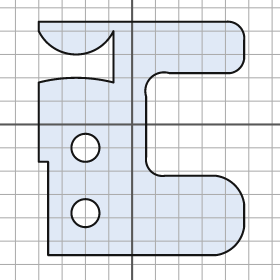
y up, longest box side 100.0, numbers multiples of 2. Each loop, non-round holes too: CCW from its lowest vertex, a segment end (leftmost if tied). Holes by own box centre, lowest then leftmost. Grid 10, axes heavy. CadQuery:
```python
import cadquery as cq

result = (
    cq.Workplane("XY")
    .moveTo(-36.0, -56.0)
    .lineTo(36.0, -56.0)
    .threePointArc((44.0, -52.0), (48.0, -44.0))
    .lineTo(48.0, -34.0)
    .threePointArc((44.0, -26.0), (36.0, -22.0))
    .lineTo(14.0, -22.0)
    .threePointArc((8.0, -20.0), (6.0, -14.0))
    .lineTo(6.0, 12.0)
    .threePointArc((8.0, 20.0), (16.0, 22.0))
    .lineTo(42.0, 22.0)
    .threePointArc((46.0, 24.0), (48.0, 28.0))
    .lineTo(48.0, 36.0)
    .threePointArc((46.0, 42.0), (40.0, 44.0))
    .lineTo(-40.0, 44.0)
    .lineTo(-40.0, 40.0)
    .threePointArc((-24.0, 30.0), (-8.0, 40.0))
    .lineTo(-8.0, 18.0)
    .threePointArc((-24.0, 20.0), (-40.0, 18.0))
    .lineTo(-40.0, -16.0)
    .lineTo(-36.0, -16.0)
    .close()
    .moveTo(-20.0, -38.0)
    .circle(6.0)
    .moveTo(-20.0, -10.0)
    .circle(6.0)
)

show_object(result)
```